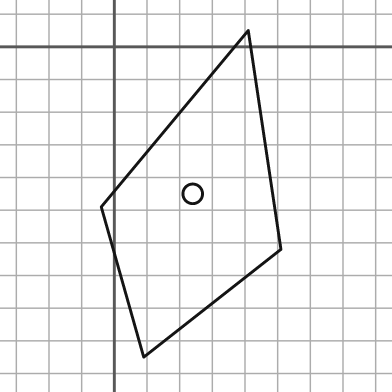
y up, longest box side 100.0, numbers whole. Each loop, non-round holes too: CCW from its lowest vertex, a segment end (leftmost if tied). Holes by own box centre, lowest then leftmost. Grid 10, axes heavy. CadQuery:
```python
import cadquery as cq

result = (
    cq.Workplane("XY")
    .moveTo(9.0, -95.0)
    .lineTo(51.0, -62.0)
    .lineTo(41.0, 5.0)
    .lineTo(-4.0, -49.0)
    .close()
    .moveTo(24.0, -45.0)
    .circle(3.0)
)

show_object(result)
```